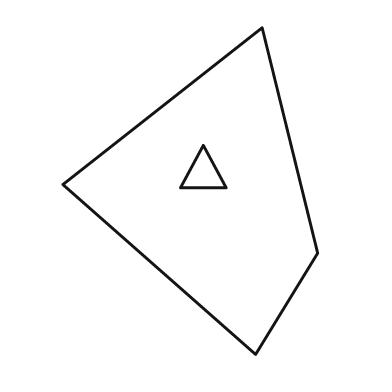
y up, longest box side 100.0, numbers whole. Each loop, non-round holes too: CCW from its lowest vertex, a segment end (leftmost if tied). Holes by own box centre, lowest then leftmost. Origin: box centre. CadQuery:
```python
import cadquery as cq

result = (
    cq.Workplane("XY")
    .moveTo(20.0, -50.0)
    .lineTo(39.0, -19.0)
    .lineTo(22.0, 50.0)
    .lineTo(-39.0, 2.0)
    .close()
    .moveTo(-3.0, 1.0)
    .lineTo(11.0, 1.0)
    .lineTo(4.0, 14.0)
    .close()
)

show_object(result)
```